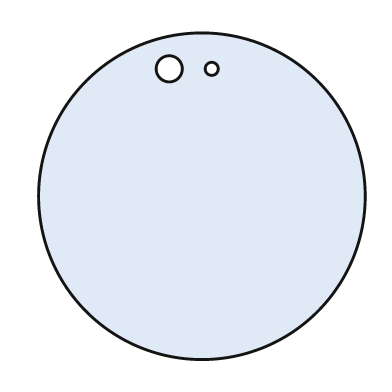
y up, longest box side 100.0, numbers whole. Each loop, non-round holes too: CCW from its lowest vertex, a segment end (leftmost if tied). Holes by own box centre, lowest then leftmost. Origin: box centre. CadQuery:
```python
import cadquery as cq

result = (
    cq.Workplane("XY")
    .moveTo(0.0, 0.0)
    .circle(50.0)
    .moveTo(-10.0, 39.0)
    .circle(4.0)
    .moveTo(3.0, 39.0)
    .circle(2.0)
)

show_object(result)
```